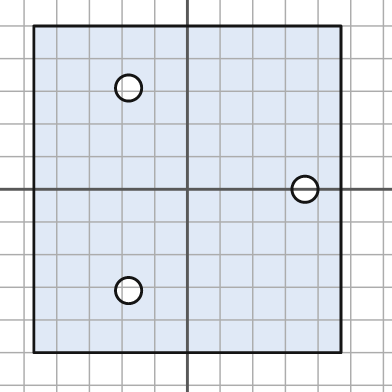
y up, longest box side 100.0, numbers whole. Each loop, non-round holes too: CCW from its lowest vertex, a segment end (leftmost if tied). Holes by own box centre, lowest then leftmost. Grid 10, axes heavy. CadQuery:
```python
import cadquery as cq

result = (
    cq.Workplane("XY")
    .moveTo(-47.0, -50.0)
    .lineTo(47.0, -50.0)
    .lineTo(47.0, 50.0)
    .lineTo(-47.0, 50.0)
    .close()
    .moveTo(-18.0, -31.0)
    .circle(4.0)
    .moveTo(36.0, 0.0)
    .circle(4.0)
    .moveTo(-18.0, 31.0)
    .circle(4.0)
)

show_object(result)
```